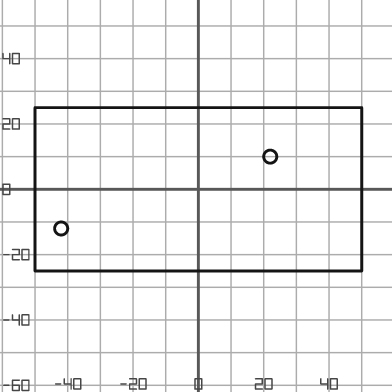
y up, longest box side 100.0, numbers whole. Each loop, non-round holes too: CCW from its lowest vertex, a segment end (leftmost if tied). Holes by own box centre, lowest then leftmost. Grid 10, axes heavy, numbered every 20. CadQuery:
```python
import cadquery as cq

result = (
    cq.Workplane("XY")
    .moveTo(-50.0, -25.0)
    .lineTo(50.0, -25.0)
    .lineTo(50.0, 25.0)
    .lineTo(-50.0, 25.0)
    .close()
    .moveTo(-42.0, -12.0)
    .circle(2.0)
    .moveTo(22.0, 10.0)
    .circle(2.0)
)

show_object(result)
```